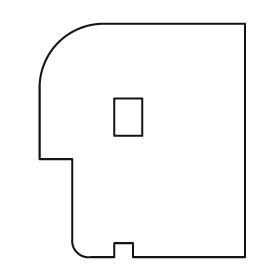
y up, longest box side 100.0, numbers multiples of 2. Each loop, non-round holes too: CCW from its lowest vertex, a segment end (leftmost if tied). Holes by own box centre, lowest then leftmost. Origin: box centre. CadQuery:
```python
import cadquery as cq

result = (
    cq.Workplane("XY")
    .moveTo(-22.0, -50.0)
    .lineTo(-12.0, -50.0)
    .lineTo(-12.0, -44.0)
    .lineTo(-4.0, -44.0)
    .lineTo(-4.0, -50.0)
    .lineTo(44.0, -50.0)
    .lineTo(44.0, 50.0)
    .lineTo(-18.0, 50.0)
    .threePointArc((-36.0, 42.0), (-44.0, 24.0))
    .lineTo(-44.0, -8.0)
    .lineTo(-30.0, -8.0)
    .lineTo(-30.0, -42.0)
    .threePointArc((-28.0, -48.0), (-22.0, -50.0))
    .close()
    .moveTo(-12.0, 2.0)
    .lineTo(0.0, 2.0)
    .lineTo(0.0, 18.0)
    .lineTo(-12.0, 18.0)
    .close()
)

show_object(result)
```